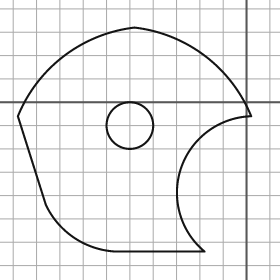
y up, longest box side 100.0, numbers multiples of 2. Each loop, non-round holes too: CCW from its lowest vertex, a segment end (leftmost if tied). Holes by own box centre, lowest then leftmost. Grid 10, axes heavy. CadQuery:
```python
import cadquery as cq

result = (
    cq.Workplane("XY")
    .moveTo(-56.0, -64.0)
    .lineTo(-18.0, -64.0)
    .threePointArc((-28.0, -28.0), (2.0, -6.0))
    .threePointArc((-18.0, 20.0), (-48.0, 32.0))
    .threePointArc((-78.0, 20.0), (-98.0, -6.0))
    .lineTo(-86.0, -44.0)
    .threePointArc((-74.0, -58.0), (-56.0, -64.0))
    .close()
    .moveTo(-50.0, -10.0)
    .circle(10.0)
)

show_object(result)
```